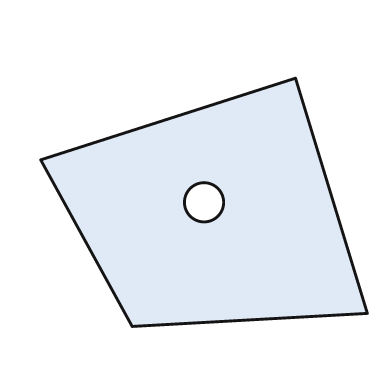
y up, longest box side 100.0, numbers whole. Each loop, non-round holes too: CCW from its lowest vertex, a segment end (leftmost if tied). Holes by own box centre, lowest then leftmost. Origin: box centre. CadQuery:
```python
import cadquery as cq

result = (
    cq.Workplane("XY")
    .moveTo(-22.0, -38.0)
    .lineTo(50.0, -34.0)
    .lineTo(28.0, 38.0)
    .lineTo(-50.0, 13.0)
    .close()
    .moveTo(0.0, 0.0)
    .circle(6.0)
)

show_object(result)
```